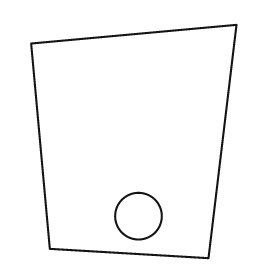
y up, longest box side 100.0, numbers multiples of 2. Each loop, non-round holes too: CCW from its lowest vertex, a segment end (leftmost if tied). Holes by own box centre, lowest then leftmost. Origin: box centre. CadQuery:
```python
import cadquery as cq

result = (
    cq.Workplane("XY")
    .moveTo(32.0, -50.0)
    .lineTo(44.0, 50.0)
    .lineTo(-44.0, 42.0)
    .lineTo(-36.0, -46.0)
    .close()
    .moveTo(2.0, -32.0)
    .circle(10.0)
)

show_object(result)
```